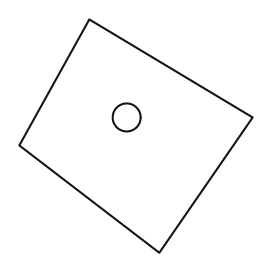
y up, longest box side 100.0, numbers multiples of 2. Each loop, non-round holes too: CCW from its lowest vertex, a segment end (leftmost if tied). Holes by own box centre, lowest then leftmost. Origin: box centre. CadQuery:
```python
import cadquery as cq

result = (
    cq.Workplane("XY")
    .moveTo(10.0, -50.0)
    .lineTo(50.0, 8.0)
    .lineTo(-20.0, 50.0)
    .lineTo(-50.0, -4.0)
    .close()
    .moveTo(-4.0, 8.0)
    .circle(6.0)
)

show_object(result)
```